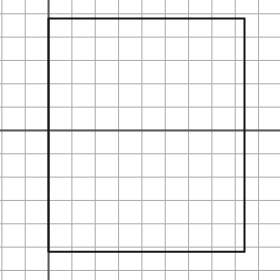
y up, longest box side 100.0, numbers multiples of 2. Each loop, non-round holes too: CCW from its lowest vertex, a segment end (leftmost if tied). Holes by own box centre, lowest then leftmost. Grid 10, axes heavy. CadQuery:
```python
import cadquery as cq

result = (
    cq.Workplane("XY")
    .moveTo(0.0, -52.0)
    .lineTo(84.0, -52.0)
    .lineTo(84.0, 48.0)
    .lineTo(0.0, 48.0)
    .close()
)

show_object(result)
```